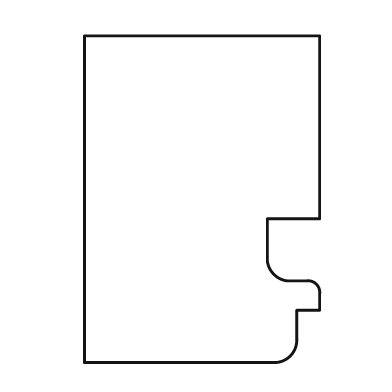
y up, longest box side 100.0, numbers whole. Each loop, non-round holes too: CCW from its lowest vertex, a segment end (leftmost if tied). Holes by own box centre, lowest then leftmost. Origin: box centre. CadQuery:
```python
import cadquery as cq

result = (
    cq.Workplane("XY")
    .moveTo(-36.0, -50.0)
    .lineTo(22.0, -50.0)
    .threePointArc((27.0, -48.0), (29.0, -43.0))
    .lineTo(29.0, -34.0)
    .lineTo(36.0, -34.0)
    .lineTo(36.0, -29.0)
    .threePointArc((35.0, -26.0), (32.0, -25.0))
    .lineTo(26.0, -25.0)
    .threePointArc((22.0, -23.0), (20.0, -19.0))
    .lineTo(20.0, -6.0)
    .lineTo(36.0, -6.0)
    .lineTo(36.0, 50.0)
    .lineTo(-36.0, 50.0)
    .close()
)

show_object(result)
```